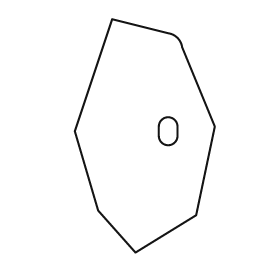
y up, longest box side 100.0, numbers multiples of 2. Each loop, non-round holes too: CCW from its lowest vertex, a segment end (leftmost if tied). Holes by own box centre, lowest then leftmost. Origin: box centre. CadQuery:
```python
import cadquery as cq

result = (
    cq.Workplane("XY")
    .moveTo(-4.0, -50.0)
    .lineTo(22.0, -34.0)
    .lineTo(30.0, 4.0)
    .lineTo(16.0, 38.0)
    .threePointArc((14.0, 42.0), (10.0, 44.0))
    .lineTo(-14.0, 50.0)
    .lineTo(-30.0, 2.0)
    .lineTo(-20.0, -32.0)
    .close()
    .moveTo(6.0, 0.0)
    .threePointArc((10.0, -4.0), (14.0, 0.0))
    .lineTo(14.0, 4.0)
    .threePointArc((10.0, 8.0), (6.0, 4.0))
    .close()
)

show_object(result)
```